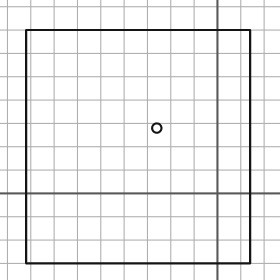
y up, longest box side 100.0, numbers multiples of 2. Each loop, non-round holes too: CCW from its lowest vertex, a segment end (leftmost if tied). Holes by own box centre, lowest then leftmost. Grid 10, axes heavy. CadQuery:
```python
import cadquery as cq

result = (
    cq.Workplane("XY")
    .moveTo(-82.0, -30.0)
    .lineTo(14.0, -30.0)
    .lineTo(14.0, 70.0)
    .lineTo(-82.0, 70.0)
    .close()
    .moveTo(-26.0, 28.0)
    .circle(2.0)
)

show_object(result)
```